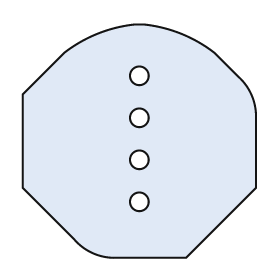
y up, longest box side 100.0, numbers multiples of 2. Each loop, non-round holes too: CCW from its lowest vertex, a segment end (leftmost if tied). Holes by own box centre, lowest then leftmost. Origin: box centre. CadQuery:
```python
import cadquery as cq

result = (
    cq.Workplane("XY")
    .moveTo(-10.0, -50.0)
    .lineTo(20.0, -50.0)
    .lineTo(50.0, -20.0)
    .lineTo(50.0, 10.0)
    .threePointArc((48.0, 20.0), (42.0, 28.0))
    .lineTo(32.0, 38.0)
    .threePointArc((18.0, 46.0), (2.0, 50.0))
    .lineTo(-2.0, 50.0)
    .threePointArc((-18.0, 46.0), (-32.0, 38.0))
    .lineTo(-50.0, 20.0)
    .lineTo(-50.0, -20.0)
    .lineTo(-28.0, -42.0)
    .threePointArc((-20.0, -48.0), (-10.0, -50.0))
    .close()
    .moveTo(0.0, -26.0)
    .circle(4.0)
    .moveTo(0.0, -8.0)
    .circle(4.0)
    .moveTo(0.0, 10.0)
    .circle(4.0)
    .moveTo(0.0, 28.0)
    .circle(4.0)
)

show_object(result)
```